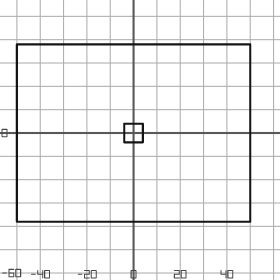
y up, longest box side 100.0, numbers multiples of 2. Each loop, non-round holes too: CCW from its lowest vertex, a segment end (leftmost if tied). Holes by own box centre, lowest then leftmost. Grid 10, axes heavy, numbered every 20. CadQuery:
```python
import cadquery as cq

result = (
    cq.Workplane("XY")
    .moveTo(-50.0, -38.0)
    .lineTo(50.0, -38.0)
    .lineTo(50.0, 38.0)
    .lineTo(-50.0, 38.0)
    .close()
    .moveTo(-4.0, -4.0)
    .lineTo(4.0, -4.0)
    .lineTo(4.0, 4.0)
    .lineTo(-4.0, 4.0)
    .close()
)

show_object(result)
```